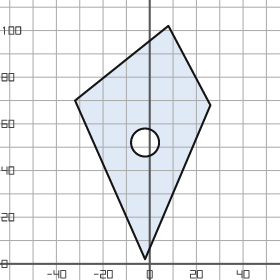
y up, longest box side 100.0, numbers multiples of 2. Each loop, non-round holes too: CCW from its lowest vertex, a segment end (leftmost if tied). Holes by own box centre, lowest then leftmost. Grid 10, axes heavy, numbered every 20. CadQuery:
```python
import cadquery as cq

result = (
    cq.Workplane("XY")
    .moveTo(-2.0, 2.0)
    .lineTo(26.0, 68.0)
    .lineTo(8.0, 102.0)
    .lineTo(-32.0, 70.0)
    .close()
    .moveTo(-2.0, 52.0)
    .circle(6.0)
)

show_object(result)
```